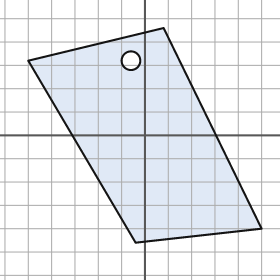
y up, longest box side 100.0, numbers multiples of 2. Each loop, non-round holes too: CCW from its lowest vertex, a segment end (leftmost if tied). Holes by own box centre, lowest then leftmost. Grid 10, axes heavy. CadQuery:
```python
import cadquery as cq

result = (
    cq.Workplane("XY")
    .moveTo(-4.0, -46.0)
    .lineTo(50.0, -40.0)
    .lineTo(8.0, 46.0)
    .lineTo(-50.0, 32.0)
    .close()
    .moveTo(-6.0, 32.0)
    .circle(4.0)
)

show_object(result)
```